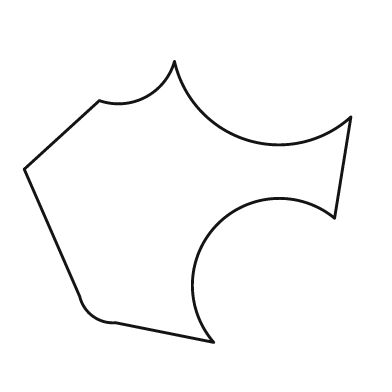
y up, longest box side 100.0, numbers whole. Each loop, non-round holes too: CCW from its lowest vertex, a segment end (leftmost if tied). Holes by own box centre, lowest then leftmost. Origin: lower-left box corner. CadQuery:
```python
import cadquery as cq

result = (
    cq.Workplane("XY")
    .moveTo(58.0, 0.0)
    .threePointArc((59.0, 36.0), (95.0, 38.0))
    .lineTo(100.0, 69.0)
    .threePointArc((68.0, 62.0), (46.0, 86.0))
    .threePointArc((37.0, 75.0), (23.0, 74.0))
    .lineTo(0.0, 53.0)
    .lineTo(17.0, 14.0)
    .threePointArc((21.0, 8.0), (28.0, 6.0))
    .close()
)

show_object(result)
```